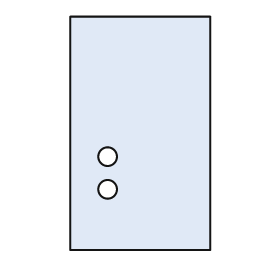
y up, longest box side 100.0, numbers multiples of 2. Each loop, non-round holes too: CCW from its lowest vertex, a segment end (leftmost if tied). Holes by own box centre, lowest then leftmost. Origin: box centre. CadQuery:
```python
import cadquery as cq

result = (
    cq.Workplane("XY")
    .moveTo(-30.0, -50.0)
    .lineTo(30.0, -50.0)
    .lineTo(30.0, 50.0)
    .lineTo(-30.0, 50.0)
    .close()
    .moveTo(-14.0, -24.0)
    .circle(4.0)
    .moveTo(-14.0, -10.0)
    .circle(4.0)
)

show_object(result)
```